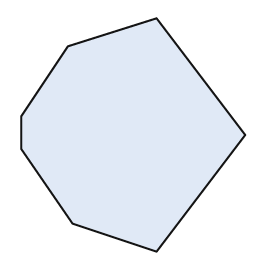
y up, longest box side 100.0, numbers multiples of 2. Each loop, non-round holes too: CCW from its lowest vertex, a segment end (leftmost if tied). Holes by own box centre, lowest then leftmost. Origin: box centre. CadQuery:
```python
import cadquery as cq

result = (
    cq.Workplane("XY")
    .moveTo(10.0, -50.0)
    .lineTo(48.0, 0.0)
    .lineTo(10.0, 50.0)
    .lineTo(-28.0, 38.0)
    .lineTo(-48.0, 8.0)
    .lineTo(-48.0, -6.0)
    .lineTo(-26.0, -38.0)
    .close()
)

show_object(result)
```